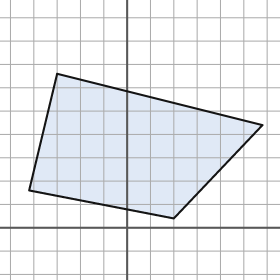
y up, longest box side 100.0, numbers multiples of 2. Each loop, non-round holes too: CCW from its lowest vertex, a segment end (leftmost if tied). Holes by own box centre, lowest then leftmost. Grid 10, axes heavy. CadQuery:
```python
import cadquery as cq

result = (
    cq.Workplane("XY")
    .moveTo(20.0, 4.0)
    .lineTo(58.0, 44.0)
    .lineTo(-30.0, 66.0)
    .lineTo(-42.0, 16.0)
    .close()
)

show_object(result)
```